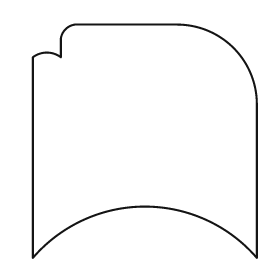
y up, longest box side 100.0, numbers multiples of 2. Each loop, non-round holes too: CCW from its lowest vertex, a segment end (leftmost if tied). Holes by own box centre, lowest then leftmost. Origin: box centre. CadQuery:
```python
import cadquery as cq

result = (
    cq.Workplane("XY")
    .moveTo(-48.0, -50.0)
    .threePointArc((0.0, -28.0), (48.0, -50.0))
    .lineTo(48.0, 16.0)
    .threePointArc((38.0, 40.0), (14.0, 50.0))
    .lineTo(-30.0, 50.0)
    .threePointArc((-34.0, 48.0), (-36.0, 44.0))
    .lineTo(-36.0, 36.0)
    .threePointArc((-42.0, 38.0), (-48.0, 36.0))
    .close()
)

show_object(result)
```